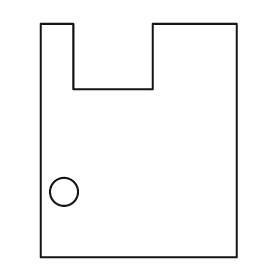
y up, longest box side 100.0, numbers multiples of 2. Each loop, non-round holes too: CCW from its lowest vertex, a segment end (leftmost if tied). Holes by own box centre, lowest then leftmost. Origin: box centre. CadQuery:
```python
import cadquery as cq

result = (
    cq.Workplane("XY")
    .moveTo(-42.0, -50.0)
    .lineTo(42.0, -50.0)
    .lineTo(42.0, 50.0)
    .lineTo(6.0, 50.0)
    .lineTo(6.0, 22.0)
    .lineTo(-28.0, 22.0)
    .lineTo(-28.0, 50.0)
    .lineTo(-42.0, 50.0)
    .close()
    .moveTo(-32.0, -22.0)
    .circle(6.0)
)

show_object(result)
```